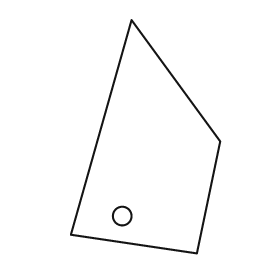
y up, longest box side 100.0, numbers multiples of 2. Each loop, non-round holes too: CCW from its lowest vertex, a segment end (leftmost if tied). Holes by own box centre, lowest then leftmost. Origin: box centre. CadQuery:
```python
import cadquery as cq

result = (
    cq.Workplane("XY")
    .moveTo(22.0, -50.0)
    .lineTo(32.0, -2.0)
    .lineTo(-6.0, 50.0)
    .lineTo(-32.0, -42.0)
    .close()
    .moveTo(-10.0, -34.0)
    .circle(4.0)
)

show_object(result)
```